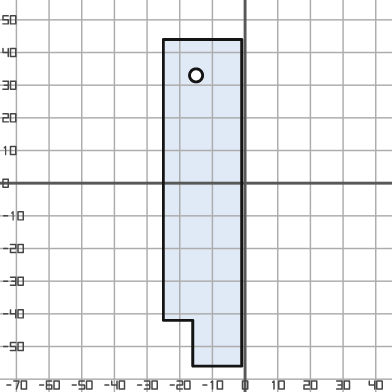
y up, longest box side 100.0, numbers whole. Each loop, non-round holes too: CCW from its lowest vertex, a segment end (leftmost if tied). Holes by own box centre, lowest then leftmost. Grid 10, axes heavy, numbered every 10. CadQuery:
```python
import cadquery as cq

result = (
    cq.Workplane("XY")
    .moveTo(-16.0, -56.0)
    .lineTo(-1.0, -56.0)
    .lineTo(-1.0, 44.0)
    .lineTo(-25.0, 44.0)
    .lineTo(-25.0, -42.0)
    .lineTo(-16.0, -42.0)
    .close()
    .moveTo(-15.0, 33.0)
    .circle(2.0)
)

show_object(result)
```